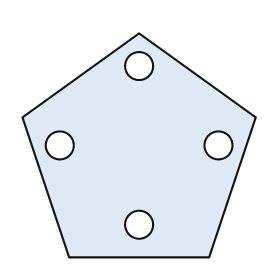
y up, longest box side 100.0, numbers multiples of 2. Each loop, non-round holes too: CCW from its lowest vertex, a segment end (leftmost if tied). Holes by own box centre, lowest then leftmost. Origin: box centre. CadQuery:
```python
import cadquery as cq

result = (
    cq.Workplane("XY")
    .moveTo(-30.0, -48.0)
    .lineTo(30.0, -48.0)
    .lineTo(50.0, 12.0)
    .lineTo(0.0, 48.0)
    .lineTo(-50.0, 12.0)
    .close()
    .moveTo(0.0, -34.0)
    .circle(6.0)
    .moveTo(-34.0, 0.0)
    .circle(6.0)
    .moveTo(34.0, 0.0)
    .circle(6.0)
    .moveTo(0.0, 34.0)
    .circle(6.0)
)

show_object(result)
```